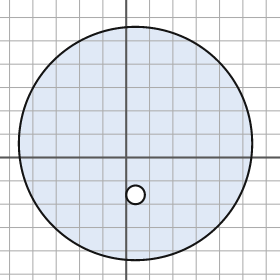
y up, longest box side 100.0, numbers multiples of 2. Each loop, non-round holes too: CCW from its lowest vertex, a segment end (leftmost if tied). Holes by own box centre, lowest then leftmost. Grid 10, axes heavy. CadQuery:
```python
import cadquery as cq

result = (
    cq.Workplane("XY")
    .moveTo(4.0, 6.0)
    .circle(50.0)
    .moveTo(4.0, -16.0)
    .circle(4.0)
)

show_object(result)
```